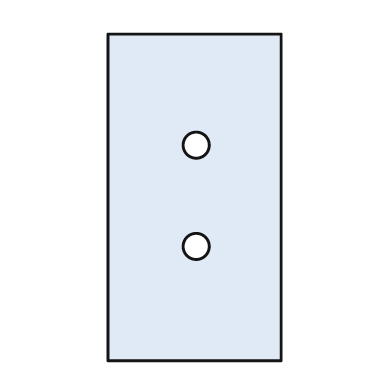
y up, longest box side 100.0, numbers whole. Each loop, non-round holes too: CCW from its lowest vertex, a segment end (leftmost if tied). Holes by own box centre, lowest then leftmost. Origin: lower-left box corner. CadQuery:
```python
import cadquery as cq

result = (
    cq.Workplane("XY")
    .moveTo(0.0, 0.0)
    .lineTo(53.0, 0.0)
    .lineTo(53.0, 100.0)
    .lineTo(0.0, 100.0)
    .close()
    .moveTo(27.0, 35.0)
    .circle(4.0)
    .moveTo(27.0, 66.0)
    .circle(4.0)
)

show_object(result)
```